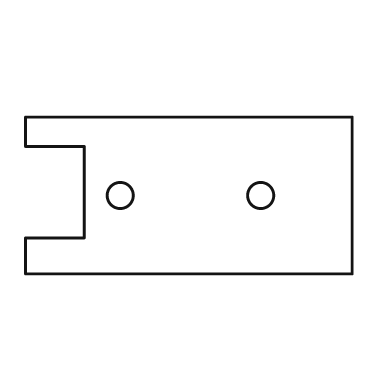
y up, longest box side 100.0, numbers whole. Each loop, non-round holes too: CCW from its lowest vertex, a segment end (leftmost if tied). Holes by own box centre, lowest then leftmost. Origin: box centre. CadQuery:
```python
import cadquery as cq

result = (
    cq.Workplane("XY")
    .moveTo(-50.0, -24.0)
    .lineTo(50.0, -24.0)
    .lineTo(50.0, 24.0)
    .lineTo(-50.0, 24.0)
    .lineTo(-50.0, 15.0)
    .lineTo(-32.0, 15.0)
    .lineTo(-32.0, -13.0)
    .lineTo(-50.0, -13.0)
    .close()
    .moveTo(-21.0, 0.0)
    .circle(4.0)
    .moveTo(22.0, 0.0)
    .circle(4.0)
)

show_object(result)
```